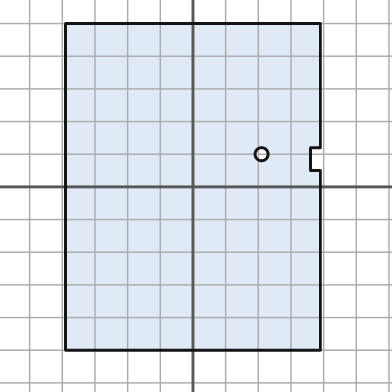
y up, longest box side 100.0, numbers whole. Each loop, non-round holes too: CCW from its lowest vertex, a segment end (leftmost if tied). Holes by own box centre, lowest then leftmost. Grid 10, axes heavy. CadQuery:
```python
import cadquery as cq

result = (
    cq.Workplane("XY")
    .moveTo(-39.0, -50.0)
    .lineTo(39.0, -50.0)
    .lineTo(39.0, 5.0)
    .lineTo(36.0, 5.0)
    .lineTo(36.0, 12.0)
    .lineTo(39.0, 12.0)
    .lineTo(39.0, 50.0)
    .lineTo(-39.0, 50.0)
    .close()
    .moveTo(21.0, 10.0)
    .circle(2.0)
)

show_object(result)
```